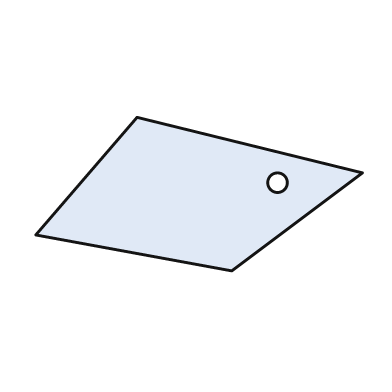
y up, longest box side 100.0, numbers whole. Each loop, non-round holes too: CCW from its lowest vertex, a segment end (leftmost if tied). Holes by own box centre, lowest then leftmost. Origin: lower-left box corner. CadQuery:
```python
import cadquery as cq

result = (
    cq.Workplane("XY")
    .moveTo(60.0, 0.0)
    .lineTo(100.0, 30.0)
    .lineTo(31.0, 47.0)
    .lineTo(0.0, 11.0)
    .close()
    .moveTo(74.0, 27.0)
    .circle(3.0)
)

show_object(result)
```